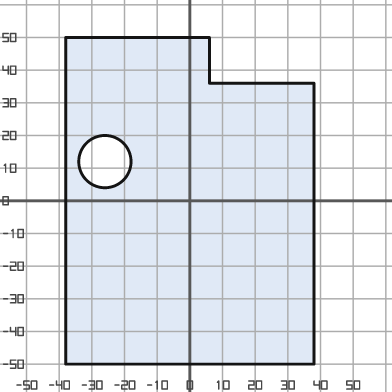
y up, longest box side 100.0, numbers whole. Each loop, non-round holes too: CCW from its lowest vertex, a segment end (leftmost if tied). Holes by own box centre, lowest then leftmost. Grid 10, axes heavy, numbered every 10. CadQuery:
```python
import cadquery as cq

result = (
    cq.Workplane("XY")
    .moveTo(-38.0, -50.0)
    .lineTo(38.0, -50.0)
    .lineTo(38.0, 36.0)
    .lineTo(6.0, 36.0)
    .lineTo(6.0, 50.0)
    .lineTo(-38.0, 50.0)
    .close()
    .moveTo(-26.0, 12.0)
    .circle(8.0)
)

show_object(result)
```